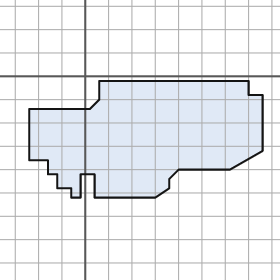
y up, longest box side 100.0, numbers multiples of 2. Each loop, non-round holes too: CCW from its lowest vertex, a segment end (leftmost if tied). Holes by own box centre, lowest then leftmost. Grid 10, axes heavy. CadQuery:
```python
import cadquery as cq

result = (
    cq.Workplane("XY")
    .moveTo(-6.0, -52.0)
    .lineTo(-2.0, -52.0)
    .lineTo(-2.0, -42.0)
    .lineTo(4.0, -42.0)
    .lineTo(4.0, -52.0)
    .lineTo(30.0, -52.0)
    .lineTo(36.0, -48.0)
    .lineTo(36.0, -44.0)
    .lineTo(40.0, -40.0)
    .lineTo(62.0, -40.0)
    .lineTo(76.0, -32.0)
    .lineTo(76.0, -8.0)
    .lineTo(70.0, -8.0)
    .lineTo(70.0, -2.0)
    .lineTo(6.0, -2.0)
    .lineTo(6.0, -10.0)
    .lineTo(2.0, -14.0)
    .lineTo(-24.0, -14.0)
    .lineTo(-24.0, -36.0)
    .lineTo(-16.0, -36.0)
    .lineTo(-16.0, -42.0)
    .lineTo(-12.0, -42.0)
    .lineTo(-12.0, -48.0)
    .lineTo(-6.0, -48.0)
    .close()
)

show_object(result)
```